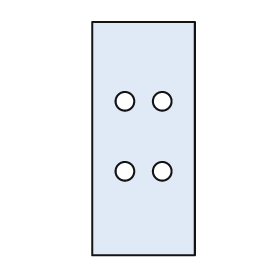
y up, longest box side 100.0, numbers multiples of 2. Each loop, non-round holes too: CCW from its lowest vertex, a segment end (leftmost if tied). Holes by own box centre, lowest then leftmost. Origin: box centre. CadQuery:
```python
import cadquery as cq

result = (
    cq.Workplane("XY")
    .moveTo(-22.0, -50.0)
    .lineTo(22.0, -50.0)
    .lineTo(22.0, 50.0)
    .lineTo(-22.0, 50.0)
    .close()
    .moveTo(-8.0, -14.0)
    .circle(4.0)
    .moveTo(8.0, -14.0)
    .circle(4.0)
    .moveTo(-8.0, 16.0)
    .circle(4.0)
    .moveTo(8.0, 16.0)
    .circle(4.0)
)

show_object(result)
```